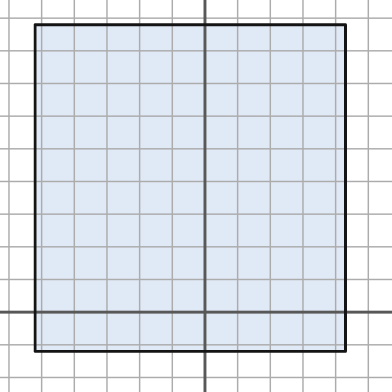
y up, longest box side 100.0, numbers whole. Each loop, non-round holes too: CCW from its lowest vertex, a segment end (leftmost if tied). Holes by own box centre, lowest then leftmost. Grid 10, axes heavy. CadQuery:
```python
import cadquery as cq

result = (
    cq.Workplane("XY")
    .moveTo(-52.0, -12.0)
    .lineTo(43.0, -12.0)
    .lineTo(43.0, 88.0)
    .lineTo(-52.0, 88.0)
    .close()
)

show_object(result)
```